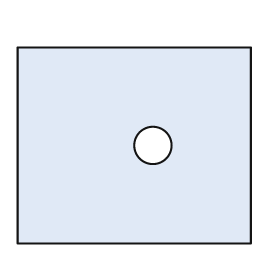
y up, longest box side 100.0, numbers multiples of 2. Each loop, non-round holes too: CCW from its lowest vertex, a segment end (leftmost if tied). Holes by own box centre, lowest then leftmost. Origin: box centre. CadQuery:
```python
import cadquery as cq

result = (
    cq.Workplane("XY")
    .moveTo(-50.0, -42.0)
    .lineTo(50.0, -42.0)
    .lineTo(50.0, 42.0)
    .lineTo(-50.0, 42.0)
    .close()
    .moveTo(8.0, 0.0)
    .circle(8.0)
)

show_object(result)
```